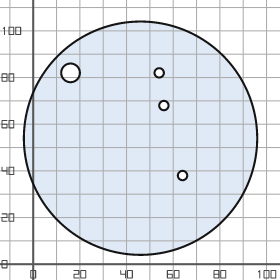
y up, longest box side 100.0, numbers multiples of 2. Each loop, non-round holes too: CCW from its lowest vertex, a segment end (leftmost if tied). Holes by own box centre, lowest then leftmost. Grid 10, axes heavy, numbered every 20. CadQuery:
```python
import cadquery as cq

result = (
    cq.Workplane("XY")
    .moveTo(46.0, 54.0)
    .circle(50.0)
    .moveTo(64.0, 38.0)
    .circle(2.0)
    .moveTo(56.0, 68.0)
    .circle(2.0)
    .moveTo(16.0, 82.0)
    .circle(4.0)
    .moveTo(54.0, 82.0)
    .circle(2.0)
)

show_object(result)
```